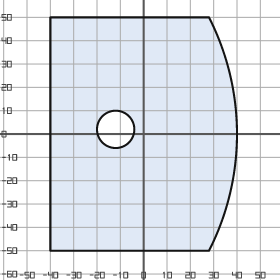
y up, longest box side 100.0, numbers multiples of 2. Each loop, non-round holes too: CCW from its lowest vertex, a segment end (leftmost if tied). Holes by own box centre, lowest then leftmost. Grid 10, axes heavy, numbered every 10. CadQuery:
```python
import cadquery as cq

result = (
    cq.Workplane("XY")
    .moveTo(-40.0, -50.0)
    .lineTo(28.0, -50.0)
    .threePointArc((40.0, 0.0), (28.0, 50.0))
    .lineTo(-40.0, 50.0)
    .close()
    .moveTo(-12.0, 2.0)
    .circle(8.0)
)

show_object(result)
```